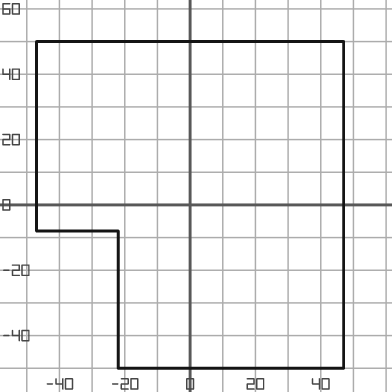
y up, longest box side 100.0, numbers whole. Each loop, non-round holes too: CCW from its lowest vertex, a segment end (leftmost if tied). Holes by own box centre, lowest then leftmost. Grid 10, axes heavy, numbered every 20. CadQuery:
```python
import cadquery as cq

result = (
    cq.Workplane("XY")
    .moveTo(-22.0, -50.0)
    .lineTo(47.0, -50.0)
    .lineTo(47.0, 50.0)
    .lineTo(-47.0, 50.0)
    .lineTo(-47.0, -8.0)
    .lineTo(-22.0, -8.0)
    .close()
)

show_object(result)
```